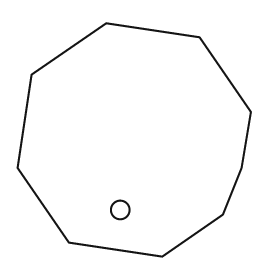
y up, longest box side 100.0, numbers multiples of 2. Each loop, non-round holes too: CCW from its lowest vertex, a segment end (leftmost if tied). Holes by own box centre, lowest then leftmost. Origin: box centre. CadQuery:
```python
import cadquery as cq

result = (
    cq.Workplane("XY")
    .moveTo(12.0, -50.0)
    .lineTo(38.0, -32.0)
    .lineTo(46.0, -12.0)
    .lineTo(50.0, 12.0)
    .lineTo(28.0, 44.0)
    .lineTo(-12.0, 50.0)
    .lineTo(-44.0, 28.0)
    .lineTo(-50.0, -12.0)
    .lineTo(-28.0, -44.0)
    .close()
    .moveTo(-6.0, -30.0)
    .circle(4.0)
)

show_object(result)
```